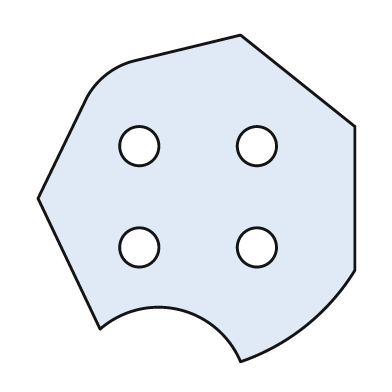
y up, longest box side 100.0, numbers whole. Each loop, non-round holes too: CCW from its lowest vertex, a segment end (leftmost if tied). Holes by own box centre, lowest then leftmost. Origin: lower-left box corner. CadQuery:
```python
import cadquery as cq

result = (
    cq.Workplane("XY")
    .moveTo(62.0, 0.0)
    .threePointArc((82.0, 11.0), (97.0, 28.0))
    .lineTo(97.0, 72.0)
    .lineTo(62.0, 100.0)
    .lineTo(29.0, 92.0)
    .threePointArc((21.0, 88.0), (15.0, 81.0))
    .lineTo(0.0, 50.0)
    .lineTo(19.0, 10.0)
    .threePointArc((43.0, 16.0), (62.0, 0.0))
    .close()
    .moveTo(31.0, 35.0)
    .circle(6.0)
    .moveTo(67.0, 35.0)
    .circle(6.0)
    .moveTo(31.0, 66.0)
    .circle(6.0)
    .moveTo(67.0, 66.0)
    .circle(6.0)
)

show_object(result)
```